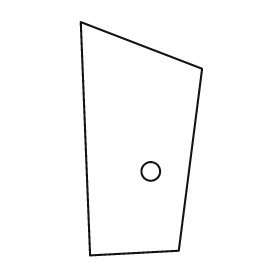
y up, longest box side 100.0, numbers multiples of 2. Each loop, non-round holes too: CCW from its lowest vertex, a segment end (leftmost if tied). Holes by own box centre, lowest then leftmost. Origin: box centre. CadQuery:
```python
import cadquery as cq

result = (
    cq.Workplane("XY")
    .moveTo(-22.0, -50.0)
    .lineTo(16.0, -48.0)
    .lineTo(26.0, 30.0)
    .lineTo(-26.0, 50.0)
    .close()
    .moveTo(4.0, -14.0)
    .circle(4.0)
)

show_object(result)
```